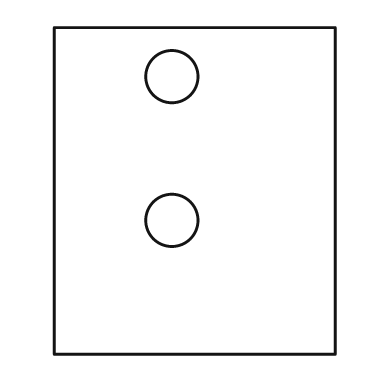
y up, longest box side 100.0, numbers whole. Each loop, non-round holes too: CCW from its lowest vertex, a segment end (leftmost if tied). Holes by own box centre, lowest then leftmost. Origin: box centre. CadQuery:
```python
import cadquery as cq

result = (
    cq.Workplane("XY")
    .moveTo(-43.0, -50.0)
    .lineTo(43.0, -50.0)
    .lineTo(43.0, 50.0)
    .lineTo(-43.0, 50.0)
    .close()
    .moveTo(-7.0, -9.0)
    .circle(8.0)
    .moveTo(-7.0, 35.0)
    .circle(8.0)
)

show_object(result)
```